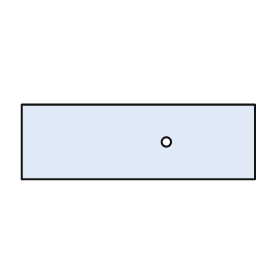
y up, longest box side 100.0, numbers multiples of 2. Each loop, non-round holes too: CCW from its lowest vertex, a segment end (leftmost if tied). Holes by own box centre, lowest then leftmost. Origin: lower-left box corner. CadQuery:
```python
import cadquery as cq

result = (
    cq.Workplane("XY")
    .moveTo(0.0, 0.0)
    .lineTo(100.0, 0.0)
    .lineTo(100.0, 32.0)
    .lineTo(0.0, 32.0)
    .close()
    .moveTo(62.0, 16.0)
    .circle(2.0)
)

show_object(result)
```